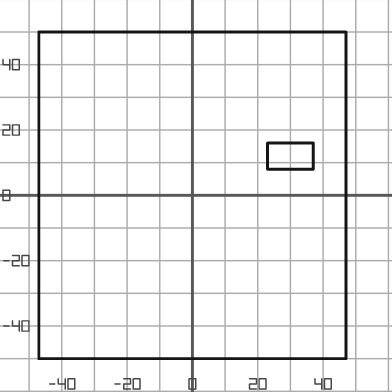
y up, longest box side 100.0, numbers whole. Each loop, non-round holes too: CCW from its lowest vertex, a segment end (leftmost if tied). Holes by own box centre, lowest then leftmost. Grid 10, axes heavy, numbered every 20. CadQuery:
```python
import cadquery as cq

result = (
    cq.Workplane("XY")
    .moveTo(-47.0, -50.0)
    .lineTo(47.0, -50.0)
    .lineTo(47.0, 50.0)
    .lineTo(-47.0, 50.0)
    .close()
    .moveTo(23.0, 8.0)
    .lineTo(37.0, 8.0)
    .lineTo(37.0, 16.0)
    .lineTo(23.0, 16.0)
    .close()
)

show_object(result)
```